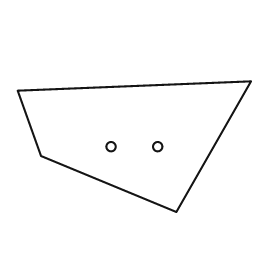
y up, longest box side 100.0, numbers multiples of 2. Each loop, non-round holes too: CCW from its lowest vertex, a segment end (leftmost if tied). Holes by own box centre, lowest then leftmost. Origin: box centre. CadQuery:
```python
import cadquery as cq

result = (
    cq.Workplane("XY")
    .moveTo(18.0, -28.0)
    .lineTo(50.0, 28.0)
    .lineTo(-50.0, 24.0)
    .lineTo(-40.0, -4.0)
    .close()
    .moveTo(-10.0, 0.0)
    .circle(2.0)
    .moveTo(10.0, 0.0)
    .circle(2.0)
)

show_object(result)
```